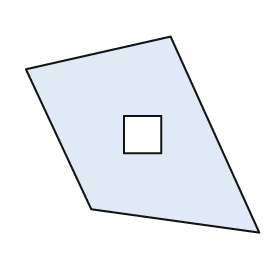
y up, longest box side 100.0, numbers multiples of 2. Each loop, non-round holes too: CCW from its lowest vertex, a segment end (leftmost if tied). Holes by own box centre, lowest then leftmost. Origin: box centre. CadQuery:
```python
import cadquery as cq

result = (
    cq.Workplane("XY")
    .moveTo(50.0, -42.0)
    .lineTo(12.0, 42.0)
    .lineTo(-50.0, 28.0)
    .lineTo(-22.0, -32.0)
    .close()
    .moveTo(-8.0, -8.0)
    .lineTo(8.0, -8.0)
    .lineTo(8.0, 8.0)
    .lineTo(-8.0, 8.0)
    .close()
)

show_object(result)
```